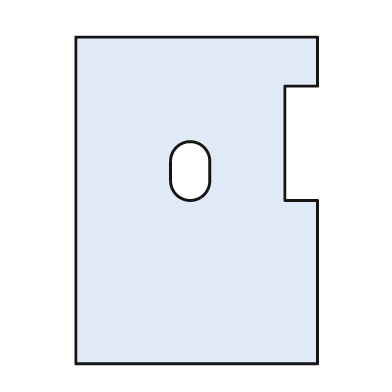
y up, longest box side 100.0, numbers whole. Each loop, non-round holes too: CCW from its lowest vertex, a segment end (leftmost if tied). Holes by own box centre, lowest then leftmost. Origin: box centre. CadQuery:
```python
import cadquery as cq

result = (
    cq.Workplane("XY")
    .moveTo(-37.0, -50.0)
    .lineTo(37.0, -50.0)
    .lineTo(37.0, 0.0)
    .lineTo(27.0, 0.0)
    .lineTo(27.0, 35.0)
    .lineTo(37.0, 35.0)
    .lineTo(37.0, 50.0)
    .lineTo(-37.0, 50.0)
    .close()
    .moveTo(-8.0, 6.0)
    .threePointArc((-2.0, 0.0), (4.0, 6.0))
    .lineTo(4.0, 12.0)
    .threePointArc((-2.0, 18.0), (-8.0, 12.0))
    .close()
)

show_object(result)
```